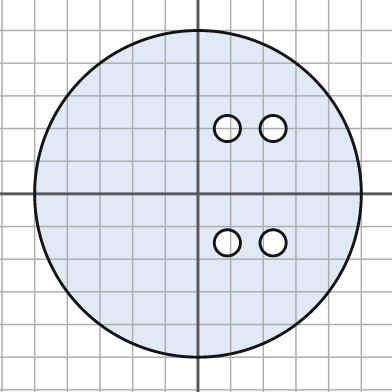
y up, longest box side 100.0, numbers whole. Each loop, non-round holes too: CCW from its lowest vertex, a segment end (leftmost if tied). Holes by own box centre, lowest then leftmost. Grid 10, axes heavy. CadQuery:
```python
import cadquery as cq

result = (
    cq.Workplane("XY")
    .moveTo(0.0, 0.0)
    .circle(50.0)
    .moveTo(9.0, -15.0)
    .circle(4.0)
    .moveTo(23.0, -15.0)
    .circle(4.0)
    .moveTo(9.0, 20.0)
    .circle(4.0)
    .moveTo(23.0, 20.0)
    .circle(4.0)
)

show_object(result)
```